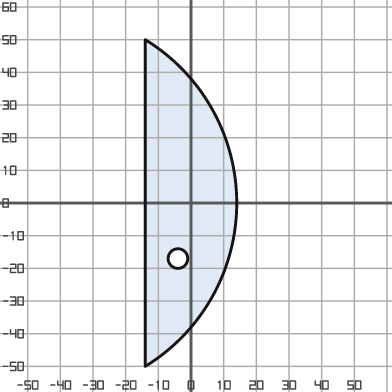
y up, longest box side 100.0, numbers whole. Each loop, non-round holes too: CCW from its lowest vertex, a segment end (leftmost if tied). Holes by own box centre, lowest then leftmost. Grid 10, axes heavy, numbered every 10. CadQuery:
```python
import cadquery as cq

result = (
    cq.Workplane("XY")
    .moveTo(-14.0, -50.0)
    .threePointArc((14.0, 0.0), (-14.0, 50.0))
    .close()
    .moveTo(-4.0, -17.0)
    .circle(3.0)
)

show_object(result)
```